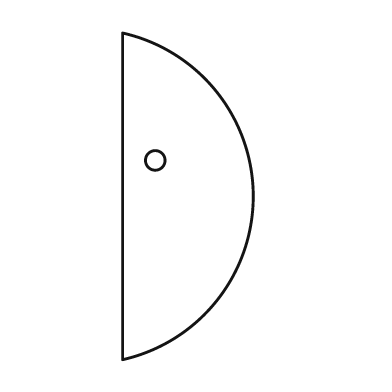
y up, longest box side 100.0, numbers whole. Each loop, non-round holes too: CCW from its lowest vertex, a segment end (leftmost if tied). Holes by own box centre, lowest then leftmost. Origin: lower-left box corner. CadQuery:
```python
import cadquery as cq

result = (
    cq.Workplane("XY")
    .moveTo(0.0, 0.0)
    .threePointArc((40.0, 50.0), (0.0, 100.0))
    .close()
    .moveTo(10.0, 61.0)
    .circle(3.0)
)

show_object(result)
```